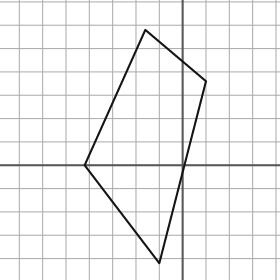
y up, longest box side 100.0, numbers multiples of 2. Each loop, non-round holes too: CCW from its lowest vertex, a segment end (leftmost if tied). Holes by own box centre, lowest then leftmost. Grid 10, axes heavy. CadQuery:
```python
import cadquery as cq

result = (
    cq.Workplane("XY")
    .moveTo(-10.0, -42.0)
    .lineTo(10.0, 36.0)
    .lineTo(-16.0, 58.0)
    .lineTo(-42.0, 0.0)
    .close()
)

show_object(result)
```